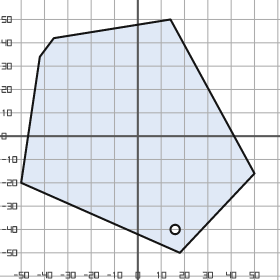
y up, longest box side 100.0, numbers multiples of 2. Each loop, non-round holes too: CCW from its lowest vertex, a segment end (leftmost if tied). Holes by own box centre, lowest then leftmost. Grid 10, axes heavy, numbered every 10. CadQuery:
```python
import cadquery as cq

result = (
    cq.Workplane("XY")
    .moveTo(18.0, -50.0)
    .lineTo(50.0, -16.0)
    .lineTo(14.0, 50.0)
    .lineTo(-36.0, 42.0)
    .lineTo(-42.0, 34.0)
    .lineTo(-50.0, -20.0)
    .close()
    .moveTo(16.0, -40.0)
    .circle(2.0)
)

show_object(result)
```